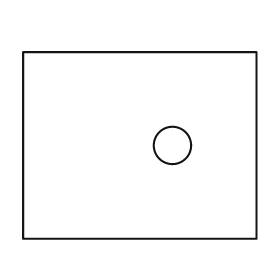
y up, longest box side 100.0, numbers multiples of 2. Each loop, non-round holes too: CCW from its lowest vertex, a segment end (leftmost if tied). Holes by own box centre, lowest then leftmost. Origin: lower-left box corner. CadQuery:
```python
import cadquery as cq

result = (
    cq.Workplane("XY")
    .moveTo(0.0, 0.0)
    .lineTo(100.0, 0.0)
    .lineTo(100.0, 80.0)
    .lineTo(0.0, 80.0)
    .close()
    .moveTo(64.0, 40.0)
    .circle(8.0)
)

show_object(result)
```